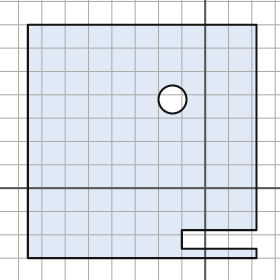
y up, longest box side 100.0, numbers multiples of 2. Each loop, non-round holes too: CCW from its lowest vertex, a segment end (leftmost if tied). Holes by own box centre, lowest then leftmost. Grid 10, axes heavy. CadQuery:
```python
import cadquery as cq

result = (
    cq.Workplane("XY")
    .moveTo(-76.0, -30.0)
    .lineTo(22.0, -30.0)
    .lineTo(22.0, -26.0)
    .lineTo(-10.0, -26.0)
    .lineTo(-10.0, -18.0)
    .lineTo(22.0, -18.0)
    .lineTo(22.0, 70.0)
    .lineTo(-76.0, 70.0)
    .close()
    .moveTo(-14.0, 38.0)
    .circle(6.0)
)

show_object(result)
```